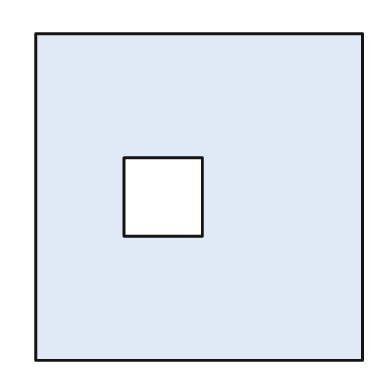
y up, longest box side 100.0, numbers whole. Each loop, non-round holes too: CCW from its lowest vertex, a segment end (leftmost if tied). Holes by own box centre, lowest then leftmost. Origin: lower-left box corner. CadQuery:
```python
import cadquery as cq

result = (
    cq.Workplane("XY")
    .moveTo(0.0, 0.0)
    .lineTo(100.0, 0.0)
    .lineTo(100.0, 100.0)
    .lineTo(0.0, 100.0)
    .close()
    .moveTo(27.0, 38.0)
    .lineTo(51.0, 38.0)
    .lineTo(51.0, 62.0)
    .lineTo(27.0, 62.0)
    .close()
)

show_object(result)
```